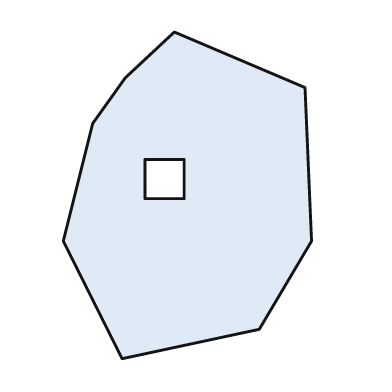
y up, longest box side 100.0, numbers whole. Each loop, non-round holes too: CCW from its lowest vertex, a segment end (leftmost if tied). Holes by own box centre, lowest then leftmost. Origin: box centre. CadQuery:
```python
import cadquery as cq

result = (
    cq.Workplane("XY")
    .moveTo(-20.0, -50.0)
    .lineTo(22.0, -41.0)
    .lineTo(38.0, -14.0)
    .lineTo(36.0, 33.0)
    .lineTo(-4.0, 50.0)
    .lineTo(-19.0, 36.0)
    .lineTo(-29.0, 22.0)
    .lineTo(-38.0, -14.0)
    .close()
    .moveTo(-13.0, -1.0)
    .lineTo(-1.0, -1.0)
    .lineTo(-1.0, 11.0)
    .lineTo(-13.0, 11.0)
    .close()
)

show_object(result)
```